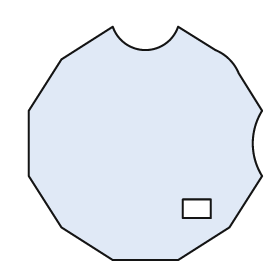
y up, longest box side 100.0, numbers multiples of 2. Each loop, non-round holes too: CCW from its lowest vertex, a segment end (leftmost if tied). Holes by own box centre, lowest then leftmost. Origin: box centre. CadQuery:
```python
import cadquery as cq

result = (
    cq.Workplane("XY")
    .moveTo(-14.0, -50.0)
    .lineTo(14.0, -50.0)
    .lineTo(36.0, -36.0)
    .lineTo(50.0, -14.0)
    .threePointArc((46.0, 0.0), (50.0, 14.0))
    .lineTo(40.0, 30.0)
    .threePointArc((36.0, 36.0), (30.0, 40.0))
    .lineTo(14.0, 50.0)
    .threePointArc((0.0, 40.0), (-14.0, 50.0))
    .lineTo(-36.0, 36.0)
    .lineTo(-50.0, 14.0)
    .lineTo(-50.0, -14.0)
    .lineTo(-36.0, -36.0)
    .close()
    .moveTo(16.0, -32.0)
    .lineTo(28.0, -32.0)
    .lineTo(28.0, -24.0)
    .lineTo(16.0, -24.0)
    .close()
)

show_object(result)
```